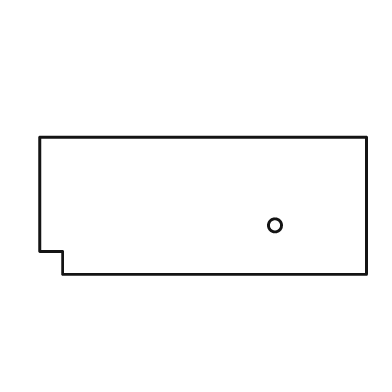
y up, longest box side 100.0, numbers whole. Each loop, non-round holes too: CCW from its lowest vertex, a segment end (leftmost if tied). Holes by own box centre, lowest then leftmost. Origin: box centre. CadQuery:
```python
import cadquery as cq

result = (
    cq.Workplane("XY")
    .moveTo(-43.0, -21.0)
    .lineTo(50.0, -21.0)
    .lineTo(50.0, 21.0)
    .lineTo(-50.0, 21.0)
    .lineTo(-50.0, -14.0)
    .lineTo(-43.0, -14.0)
    .close()
    .moveTo(22.0, -6.0)
    .circle(2.0)
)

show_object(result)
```